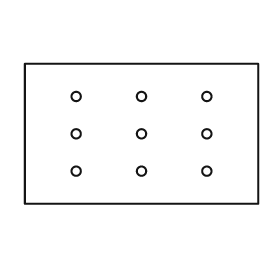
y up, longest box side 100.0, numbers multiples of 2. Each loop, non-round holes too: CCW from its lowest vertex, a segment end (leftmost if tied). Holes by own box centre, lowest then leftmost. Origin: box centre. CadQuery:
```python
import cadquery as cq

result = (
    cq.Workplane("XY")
    .moveTo(-50.0, -30.0)
    .lineTo(50.0, -30.0)
    .lineTo(50.0, 30.0)
    .lineTo(-50.0, 30.0)
    .close()
    .moveTo(-28.0, -16.0)
    .circle(2.0)
    .moveTo(0.0, -16.0)
    .circle(2.0)
    .moveTo(28.0, -16.0)
    .circle(2.0)
    .moveTo(-28.0, 0.0)
    .circle(2.0)
    .moveTo(0.0, 0.0)
    .circle(2.0)
    .moveTo(28.0, 0.0)
    .circle(2.0)
    .moveTo(-28.0, 16.0)
    .circle(2.0)
    .moveTo(0.0, 16.0)
    .circle(2.0)
    .moveTo(28.0, 16.0)
    .circle(2.0)
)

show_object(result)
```